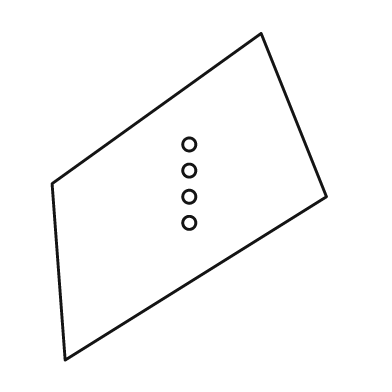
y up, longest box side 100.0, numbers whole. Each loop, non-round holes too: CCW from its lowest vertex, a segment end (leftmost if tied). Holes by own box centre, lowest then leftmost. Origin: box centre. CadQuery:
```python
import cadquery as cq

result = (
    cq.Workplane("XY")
    .moveTo(-38.0, -50.0)
    .lineTo(42.0, 0.0)
    .lineTo(22.0, 50.0)
    .lineTo(-42.0, 4.0)
    .close()
    .moveTo(0.0, -8.0)
    .circle(2.0)
    .moveTo(0.0, 0.0)
    .circle(2.0)
    .moveTo(0.0, 8.0)
    .circle(2.0)
    .moveTo(0.0, 16.0)
    .circle(2.0)
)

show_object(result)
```